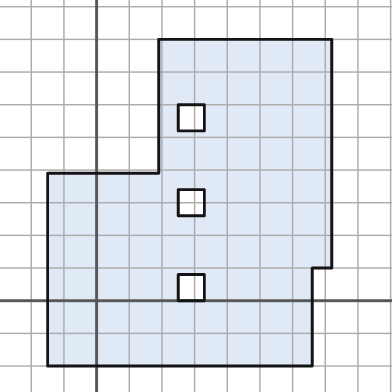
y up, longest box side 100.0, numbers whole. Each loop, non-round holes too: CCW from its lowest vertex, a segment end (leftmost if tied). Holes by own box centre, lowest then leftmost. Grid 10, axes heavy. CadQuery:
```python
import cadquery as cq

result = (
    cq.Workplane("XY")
    .moveTo(-15.0, -20.0)
    .lineTo(66.0, -20.0)
    .lineTo(66.0, 10.0)
    .lineTo(72.0, 10.0)
    .lineTo(72.0, 80.0)
    .lineTo(19.0, 80.0)
    .lineTo(19.0, 39.0)
    .lineTo(-15.0, 39.0)
    .close()
    .moveTo(25.0, 0.0)
    .lineTo(33.0, 0.0)
    .lineTo(33.0, 8.0)
    .lineTo(25.0, 8.0)
    .close()
    .moveTo(25.0, 26.0)
    .lineTo(33.0, 26.0)
    .lineTo(33.0, 34.0)
    .lineTo(25.0, 34.0)
    .close()
    .moveTo(25.0, 52.0)
    .lineTo(33.0, 52.0)
    .lineTo(33.0, 60.0)
    .lineTo(25.0, 60.0)
    .close()
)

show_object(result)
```